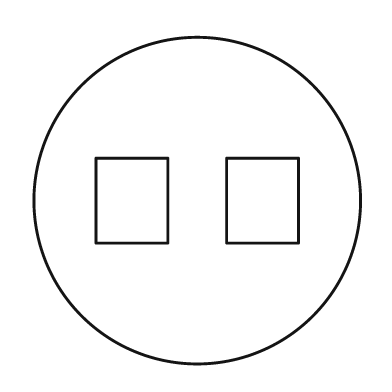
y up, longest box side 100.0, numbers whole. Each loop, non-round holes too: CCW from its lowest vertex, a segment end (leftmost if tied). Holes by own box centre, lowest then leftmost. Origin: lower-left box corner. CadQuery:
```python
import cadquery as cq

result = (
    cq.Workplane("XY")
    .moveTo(50.0, 50.0)
    .circle(50.0)
    .moveTo(19.0, 37.0)
    .lineTo(41.0, 37.0)
    .lineTo(41.0, 63.0)
    .lineTo(19.0, 63.0)
    .close()
    .moveTo(59.0, 37.0)
    .lineTo(81.0, 37.0)
    .lineTo(81.0, 63.0)
    .lineTo(59.0, 63.0)
    .close()
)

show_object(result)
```